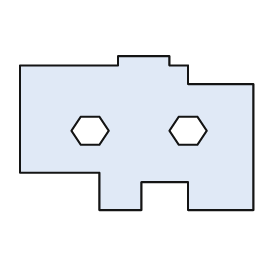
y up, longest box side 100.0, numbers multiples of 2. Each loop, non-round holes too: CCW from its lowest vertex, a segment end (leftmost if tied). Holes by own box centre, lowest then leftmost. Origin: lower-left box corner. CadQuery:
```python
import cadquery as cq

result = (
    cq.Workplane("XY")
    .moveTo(34.0, 0.0)
    .lineTo(52.0, 0.0)
    .lineTo(52.0, 12.0)
    .lineTo(72.0, 12.0)
    .lineTo(72.0, 0.0)
    .lineTo(100.0, 0.0)
    .lineTo(100.0, 54.0)
    .lineTo(72.0, 54.0)
    .lineTo(72.0, 62.0)
    .lineTo(64.0, 62.0)
    .lineTo(64.0, 66.0)
    .lineTo(42.0, 66.0)
    .lineTo(42.0, 62.0)
    .lineTo(0.0, 62.0)
    .lineTo(0.0, 16.0)
    .lineTo(34.0, 16.0)
    .close()
    .moveTo(26.0, 28.0)
    .lineTo(34.0, 28.0)
    .lineTo(38.0, 34.0)
    .lineTo(34.0, 40.0)
    .lineTo(26.0, 40.0)
    .lineTo(22.0, 34.0)
    .close()
    .moveTo(68.0, 28.0)
    .lineTo(76.0, 28.0)
    .lineTo(80.0, 34.0)
    .lineTo(76.0, 40.0)
    .lineTo(68.0, 40.0)
    .lineTo(64.0, 34.0)
    .close()
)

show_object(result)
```